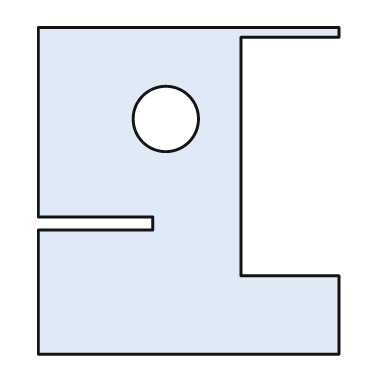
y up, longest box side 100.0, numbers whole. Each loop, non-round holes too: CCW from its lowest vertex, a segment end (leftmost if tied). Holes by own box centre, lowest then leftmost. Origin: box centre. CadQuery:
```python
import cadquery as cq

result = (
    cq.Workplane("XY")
    .moveTo(-46.0, -50.0)
    .lineTo(46.0, -50.0)
    .lineTo(46.0, -26.0)
    .lineTo(16.0, -26.0)
    .lineTo(16.0, 47.0)
    .lineTo(46.0, 47.0)
    .lineTo(46.0, 50.0)
    .lineTo(-46.0, 50.0)
    .lineTo(-46.0, -8.0)
    .lineTo(-11.0, -8.0)
    .lineTo(-11.0, -12.0)
    .lineTo(-46.0, -12.0)
    .close()
    .moveTo(-7.0, 22.0)
    .circle(10.0)
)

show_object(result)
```